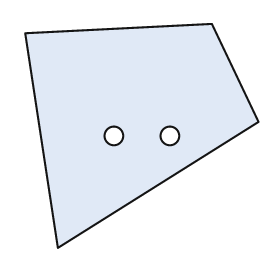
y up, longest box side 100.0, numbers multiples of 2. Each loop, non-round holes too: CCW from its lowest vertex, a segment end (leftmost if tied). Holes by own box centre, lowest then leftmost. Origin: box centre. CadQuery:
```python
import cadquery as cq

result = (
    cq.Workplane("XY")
    .moveTo(-36.0, -48.0)
    .lineTo(50.0, 6.0)
    .lineTo(30.0, 48.0)
    .lineTo(-50.0, 44.0)
    .close()
    .moveTo(-12.0, 0.0)
    .circle(4.0)
    .moveTo(12.0, 0.0)
    .circle(4.0)
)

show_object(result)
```